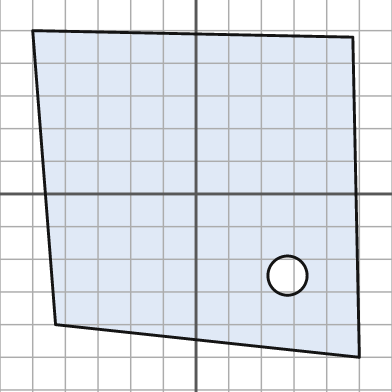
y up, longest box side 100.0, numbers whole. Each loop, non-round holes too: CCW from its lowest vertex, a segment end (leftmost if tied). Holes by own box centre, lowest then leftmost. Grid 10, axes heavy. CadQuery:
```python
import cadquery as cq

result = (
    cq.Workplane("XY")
    .moveTo(50.0, -50.0)
    .lineTo(48.0, 48.0)
    .lineTo(-50.0, 50.0)
    .lineTo(-43.0, -40.0)
    .close()
    .moveTo(28.0, -25.0)
    .circle(6.0)
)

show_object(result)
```